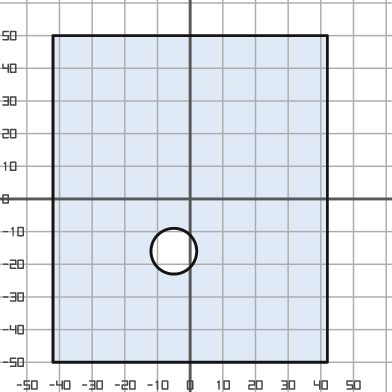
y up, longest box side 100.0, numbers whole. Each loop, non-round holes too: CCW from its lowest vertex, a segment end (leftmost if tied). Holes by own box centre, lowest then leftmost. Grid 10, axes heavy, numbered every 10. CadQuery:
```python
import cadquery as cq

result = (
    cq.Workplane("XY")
    .moveTo(-42.0, -50.0)
    .lineTo(42.0, -50.0)
    .lineTo(42.0, 50.0)
    .lineTo(-42.0, 50.0)
    .close()
    .moveTo(-5.0, -16.0)
    .circle(7.0)
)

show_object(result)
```